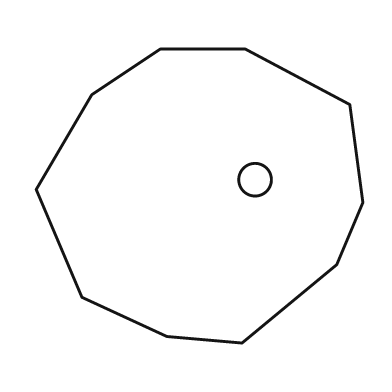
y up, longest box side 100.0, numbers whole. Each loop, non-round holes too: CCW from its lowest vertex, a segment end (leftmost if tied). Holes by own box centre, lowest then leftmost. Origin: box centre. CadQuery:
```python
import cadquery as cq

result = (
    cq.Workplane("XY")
    .moveTo(13.0, -45.0)
    .lineTo(42.0, -21.0)
    .lineTo(50.0, -2.0)
    .lineTo(46.0, 28.0)
    .lineTo(14.0, 45.0)
    .lineTo(-12.0, 45.0)
    .lineTo(-33.0, 31.0)
    .lineTo(-50.0, 2.0)
    .lineTo(-36.0, -31.0)
    .lineTo(-10.0, -43.0)
    .close()
    .moveTo(17.0, 5.0)
    .circle(5.0)
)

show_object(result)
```